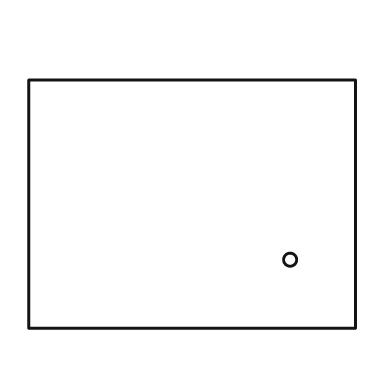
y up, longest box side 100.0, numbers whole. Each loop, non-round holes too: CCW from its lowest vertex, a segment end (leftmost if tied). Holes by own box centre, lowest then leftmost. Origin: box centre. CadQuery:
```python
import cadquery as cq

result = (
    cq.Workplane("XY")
    .moveTo(-50.0, -38.0)
    .lineTo(50.0, -38.0)
    .lineTo(50.0, 38.0)
    .lineTo(-50.0, 38.0)
    .close()
    .moveTo(30.0, -17.0)
    .circle(2.0)
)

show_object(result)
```